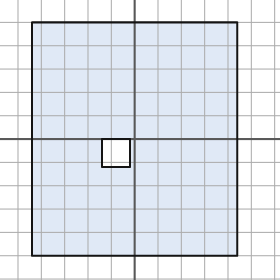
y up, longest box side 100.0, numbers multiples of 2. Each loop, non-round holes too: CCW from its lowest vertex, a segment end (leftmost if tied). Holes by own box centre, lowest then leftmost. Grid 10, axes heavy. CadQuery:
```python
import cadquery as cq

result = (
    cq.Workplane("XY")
    .moveTo(-44.0, -50.0)
    .lineTo(44.0, -50.0)
    .lineTo(44.0, 50.0)
    .lineTo(-44.0, 50.0)
    .close()
    .moveTo(-14.0, -12.0)
    .lineTo(-2.0, -12.0)
    .lineTo(-2.0, 0.0)
    .lineTo(-14.0, 0.0)
    .close()
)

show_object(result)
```